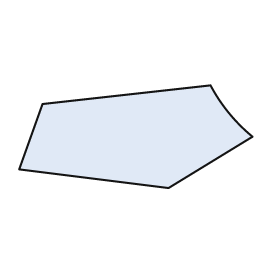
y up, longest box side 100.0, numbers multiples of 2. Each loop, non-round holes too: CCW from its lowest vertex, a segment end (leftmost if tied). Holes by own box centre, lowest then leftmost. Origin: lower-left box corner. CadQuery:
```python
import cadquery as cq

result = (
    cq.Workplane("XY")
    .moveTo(64.0, 0.0)
    .lineTo(100.0, 22.0)
    .threePointArc((90.0, 32.0), (82.0, 44.0))
    .lineTo(10.0, 36.0)
    .lineTo(0.0, 8.0)
    .close()
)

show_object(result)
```